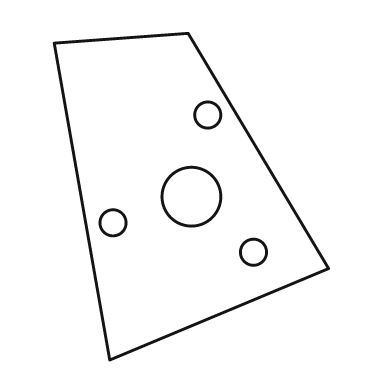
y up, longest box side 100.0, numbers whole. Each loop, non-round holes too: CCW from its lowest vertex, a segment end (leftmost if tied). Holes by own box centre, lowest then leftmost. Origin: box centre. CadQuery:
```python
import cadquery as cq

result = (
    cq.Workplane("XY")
    .moveTo(-25.0, -50.0)
    .lineTo(42.0, -22.0)
    .lineTo(-1.0, 50.0)
    .lineTo(-42.0, 47.0)
    .close()
    .moveTo(19.0, -17.0)
    .circle(4.0)
    .moveTo(-24.0, -8.0)
    .circle(4.0)
    .moveTo(0.0, 0.0)
    .circle(9.0)
    .moveTo(5.0, 25.0)
    .circle(4.0)
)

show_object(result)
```